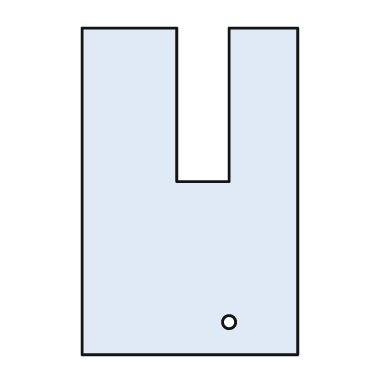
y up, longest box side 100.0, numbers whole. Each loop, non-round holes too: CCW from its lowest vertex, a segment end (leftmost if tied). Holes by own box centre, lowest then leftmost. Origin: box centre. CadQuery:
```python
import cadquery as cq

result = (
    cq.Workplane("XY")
    .moveTo(-33.0, -50.0)
    .lineTo(33.0, -50.0)
    .lineTo(33.0, 50.0)
    .lineTo(12.0, 50.0)
    .lineTo(12.0, 3.0)
    .lineTo(-4.0, 3.0)
    .lineTo(-4.0, 50.0)
    .lineTo(-33.0, 50.0)
    .close()
    .moveTo(12.0, -40.0)
    .circle(2.0)
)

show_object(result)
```